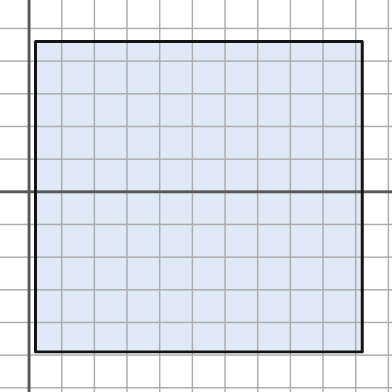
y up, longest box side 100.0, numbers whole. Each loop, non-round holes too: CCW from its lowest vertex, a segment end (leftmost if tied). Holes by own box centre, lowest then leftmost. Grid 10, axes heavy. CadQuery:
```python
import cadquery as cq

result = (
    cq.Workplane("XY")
    .moveTo(2.0, -49.0)
    .lineTo(102.0, -49.0)
    .lineTo(102.0, 46.0)
    .lineTo(2.0, 46.0)
    .close()
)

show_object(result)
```